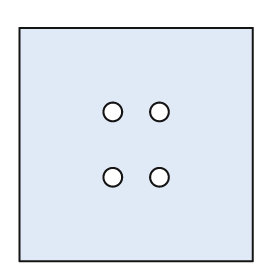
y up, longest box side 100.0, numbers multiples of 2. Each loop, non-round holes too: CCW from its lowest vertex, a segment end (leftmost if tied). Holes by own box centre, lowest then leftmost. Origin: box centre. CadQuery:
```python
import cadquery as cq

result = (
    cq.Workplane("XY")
    .moveTo(-50.0, -50.0)
    .lineTo(50.0, -50.0)
    .lineTo(50.0, 50.0)
    .lineTo(-50.0, 50.0)
    .close()
    .moveTo(-10.0, -14.0)
    .circle(4.0)
    .moveTo(10.0, -14.0)
    .circle(4.0)
    .moveTo(-10.0, 14.0)
    .circle(4.0)
    .moveTo(10.0, 14.0)
    .circle(4.0)
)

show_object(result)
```